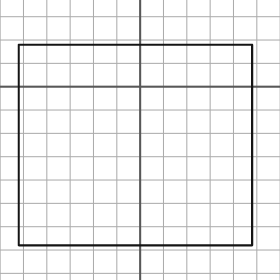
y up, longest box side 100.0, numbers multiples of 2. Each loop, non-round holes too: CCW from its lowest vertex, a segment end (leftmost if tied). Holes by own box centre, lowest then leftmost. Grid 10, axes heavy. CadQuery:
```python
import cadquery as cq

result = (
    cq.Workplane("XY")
    .moveTo(-52.0, -68.0)
    .lineTo(48.0, -68.0)
    .lineTo(48.0, 18.0)
    .lineTo(-52.0, 18.0)
    .close()
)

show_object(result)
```